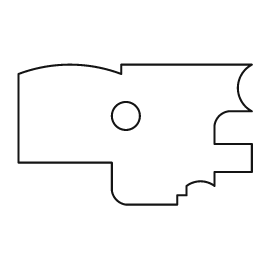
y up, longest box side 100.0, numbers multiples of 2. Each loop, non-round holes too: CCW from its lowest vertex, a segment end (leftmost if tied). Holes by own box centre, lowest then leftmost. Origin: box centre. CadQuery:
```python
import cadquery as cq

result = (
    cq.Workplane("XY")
    .moveTo(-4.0, -30.0)
    .lineTo(18.0, -30.0)
    .lineTo(18.0, -26.0)
    .lineTo(22.0, -26.0)
    .lineTo(22.0, -22.0)
    .threePointArc((28.0, -20.0), (34.0, -22.0))
    .lineTo(34.0, -16.0)
    .lineTo(50.0, -16.0)
    .lineTo(50.0, -4.0)
    .lineTo(34.0, -4.0)
    .lineTo(34.0, 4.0)
    .threePointArc((36.0, 8.0), (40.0, 10.0))
    .lineTo(50.0, 10.0)
    .threePointArc((44.0, 20.0), (50.0, 30.0))
    .lineTo(-6.0, 30.0)
    .lineTo(-6.0, 26.0)
    .threePointArc((-28.0, 30.0), (-50.0, 26.0))
    .lineTo(-50.0, -12.0)
    .lineTo(-10.0, -12.0)
    .lineTo(-10.0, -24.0)
    .threePointArc((-8.0, -28.0), (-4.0, -30.0))
    .close()
    .moveTo(-4.0, 8.0)
    .circle(6.0)
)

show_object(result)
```